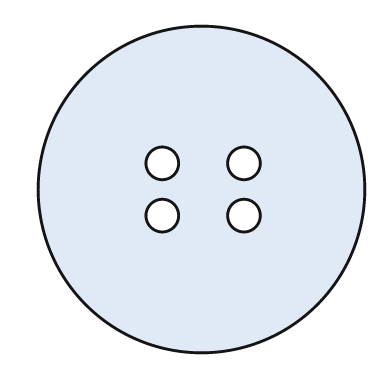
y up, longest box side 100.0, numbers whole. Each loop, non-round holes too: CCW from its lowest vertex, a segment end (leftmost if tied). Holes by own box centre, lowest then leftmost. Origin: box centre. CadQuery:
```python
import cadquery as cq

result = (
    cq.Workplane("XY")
    .moveTo(0.0, 0.0)
    .circle(50.0)
    .moveTo(-12.0, -8.0)
    .circle(5.0)
    .moveTo(13.0, -8.0)
    .circle(5.0)
    .moveTo(-12.0, 8.0)
    .circle(5.0)
    .moveTo(13.0, 8.0)
    .circle(5.0)
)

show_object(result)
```